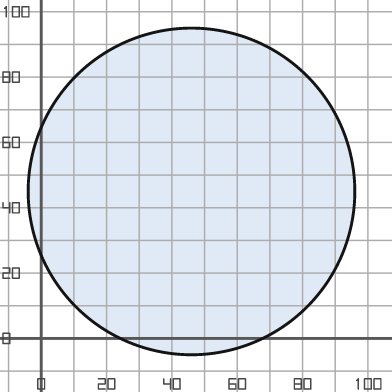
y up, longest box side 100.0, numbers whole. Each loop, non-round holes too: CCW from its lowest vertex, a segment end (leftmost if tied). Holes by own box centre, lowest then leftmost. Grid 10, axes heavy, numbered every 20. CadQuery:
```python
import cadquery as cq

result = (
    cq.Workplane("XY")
    .moveTo(46.0, 45.0)
    .circle(50.0)
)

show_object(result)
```